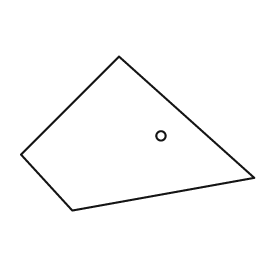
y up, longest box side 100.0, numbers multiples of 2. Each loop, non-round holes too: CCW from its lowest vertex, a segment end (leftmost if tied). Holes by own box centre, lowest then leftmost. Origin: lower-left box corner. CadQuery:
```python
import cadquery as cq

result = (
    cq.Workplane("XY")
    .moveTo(22.0, 0.0)
    .lineTo(100.0, 14.0)
    .lineTo(42.0, 66.0)
    .lineTo(0.0, 24.0)
    .close()
    .moveTo(60.0, 32.0)
    .circle(2.0)
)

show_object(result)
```